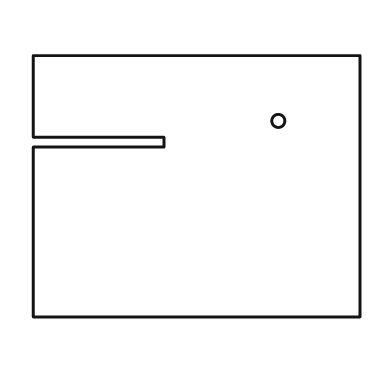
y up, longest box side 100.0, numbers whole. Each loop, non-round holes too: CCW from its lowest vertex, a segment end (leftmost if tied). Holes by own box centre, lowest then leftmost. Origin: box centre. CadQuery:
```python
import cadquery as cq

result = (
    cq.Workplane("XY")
    .moveTo(-50.0, -40.0)
    .lineTo(50.0, -40.0)
    .lineTo(50.0, 40.0)
    .lineTo(-50.0, 40.0)
    .lineTo(-50.0, 15.0)
    .lineTo(-10.0, 15.0)
    .lineTo(-10.0, 12.0)
    .lineTo(-50.0, 12.0)
    .close()
    .moveTo(25.0, 20.0)
    .circle(2.0)
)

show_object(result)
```